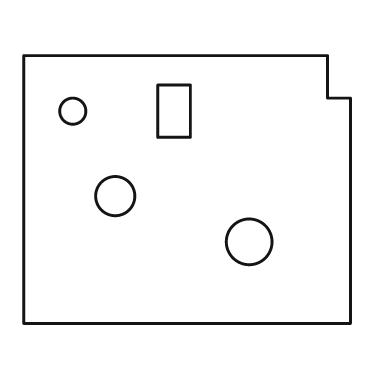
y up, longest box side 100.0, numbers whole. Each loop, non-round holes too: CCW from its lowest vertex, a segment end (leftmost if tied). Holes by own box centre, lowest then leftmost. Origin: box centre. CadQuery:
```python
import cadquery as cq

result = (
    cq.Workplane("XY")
    .moveTo(-50.0, -41.0)
    .lineTo(50.0, -41.0)
    .lineTo(50.0, 28.0)
    .lineTo(43.0, 28.0)
    .lineTo(43.0, 41.0)
    .lineTo(-50.0, 41.0)
    .close()
    .moveTo(19.0, -16.0)
    .circle(7.0)
    .moveTo(-22.0, -2.0)
    .circle(6.0)
    .moveTo(-35.0, 24.0)
    .circle(4.0)
    .moveTo(-9.0, 16.0)
    .lineTo(1.0, 16.0)
    .lineTo(1.0, 32.0)
    .lineTo(-9.0, 32.0)
    .close()
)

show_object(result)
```